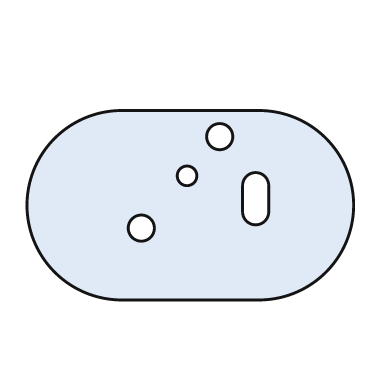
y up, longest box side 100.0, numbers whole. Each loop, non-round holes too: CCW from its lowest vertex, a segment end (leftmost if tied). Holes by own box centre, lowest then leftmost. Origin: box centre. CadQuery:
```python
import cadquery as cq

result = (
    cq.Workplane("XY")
    .moveTo(-21.0, -29.0)
    .lineTo(21.0, -29.0)
    .threePointArc((50.0, 0.0), (21.0, 29.0))
    .lineTo(-21.0, 29.0)
    .threePointArc((-50.0, 0.0), (-21.0, -29.0))
    .close()
    .moveTo(-15.0, -7.0)
    .circle(4.0)
    .moveTo(16.0, -2.0)
    .threePointArc((20.0, -6.0), (24.0, -2.0))
    .lineTo(24.0, 6.0)
    .threePointArc((20.0, 10.0), (16.0, 6.0))
    .close()
    .moveTo(-1.0, 9.0)
    .circle(3.0)
    .moveTo(9.0, 21.0)
    .circle(4.0)
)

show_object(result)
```